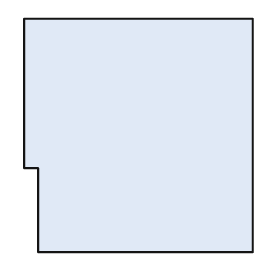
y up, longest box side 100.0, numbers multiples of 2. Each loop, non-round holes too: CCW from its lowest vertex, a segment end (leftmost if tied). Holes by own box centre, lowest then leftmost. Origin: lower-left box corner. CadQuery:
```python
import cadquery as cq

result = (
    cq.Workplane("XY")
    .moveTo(6.0, 0.0)
    .lineTo(98.0, 0.0)
    .lineTo(98.0, 100.0)
    .lineTo(0.0, 100.0)
    .lineTo(0.0, 36.0)
    .lineTo(6.0, 36.0)
    .close()
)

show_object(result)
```